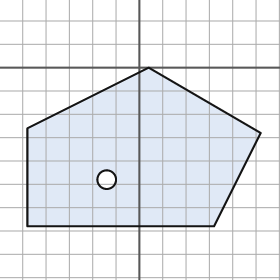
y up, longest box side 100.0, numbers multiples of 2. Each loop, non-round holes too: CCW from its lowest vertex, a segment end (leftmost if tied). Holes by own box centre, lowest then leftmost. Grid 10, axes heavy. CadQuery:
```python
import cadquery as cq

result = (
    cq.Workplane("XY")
    .moveTo(-48.0, -68.0)
    .lineTo(32.0, -68.0)
    .lineTo(52.0, -28.0)
    .lineTo(4.0, 0.0)
    .lineTo(-48.0, -26.0)
    .close()
    .moveTo(-14.0, -48.0)
    .circle(4.0)
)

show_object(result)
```